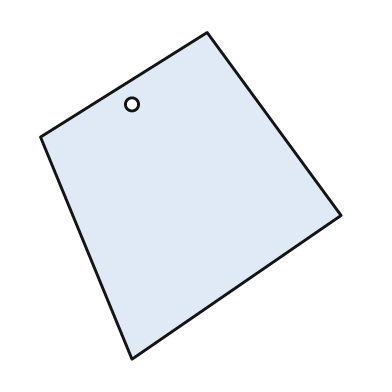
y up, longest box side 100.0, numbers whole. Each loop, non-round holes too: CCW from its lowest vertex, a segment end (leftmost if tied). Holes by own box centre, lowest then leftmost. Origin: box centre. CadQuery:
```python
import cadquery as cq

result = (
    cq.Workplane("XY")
    .moveTo(-18.0, -50.0)
    .lineTo(46.0, -6.0)
    .lineTo(5.0, 50.0)
    .lineTo(-46.0, 18.0)
    .close()
    .moveTo(-18.0, 28.0)
    .circle(2.0)
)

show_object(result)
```